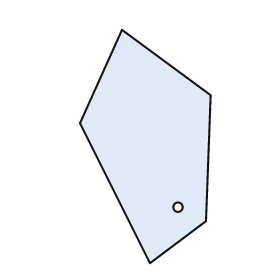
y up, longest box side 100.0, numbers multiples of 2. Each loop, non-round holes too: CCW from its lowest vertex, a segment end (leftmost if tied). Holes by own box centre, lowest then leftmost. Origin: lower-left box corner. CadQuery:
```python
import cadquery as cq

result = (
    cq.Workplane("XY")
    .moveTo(30.0, 0.0)
    .lineTo(54.0, 18.0)
    .lineTo(56.0, 72.0)
    .lineTo(18.0, 100.0)
    .lineTo(0.0, 60.0)
    .close()
    .moveTo(42.0, 24.0)
    .circle(2.0)
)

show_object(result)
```